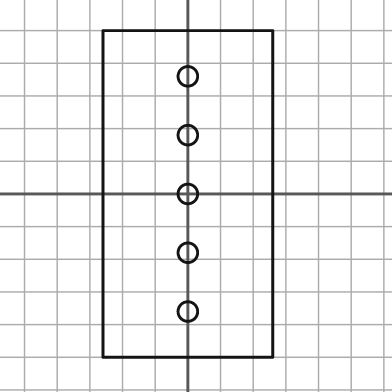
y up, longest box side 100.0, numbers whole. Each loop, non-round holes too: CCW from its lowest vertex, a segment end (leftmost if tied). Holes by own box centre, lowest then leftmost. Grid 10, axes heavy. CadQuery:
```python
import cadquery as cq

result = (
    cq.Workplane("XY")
    .moveTo(-26.0, -50.0)
    .lineTo(26.0, -50.0)
    .lineTo(26.0, 50.0)
    .lineTo(-26.0, 50.0)
    .close()
    .moveTo(0.0, -36.0)
    .circle(3.0)
    .moveTo(0.0, -18.0)
    .circle(3.0)
    .moveTo(0.0, 0.0)
    .circle(3.0)
    .moveTo(0.0, 18.0)
    .circle(3.0)
    .moveTo(0.0, 36.0)
    .circle(3.0)
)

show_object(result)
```